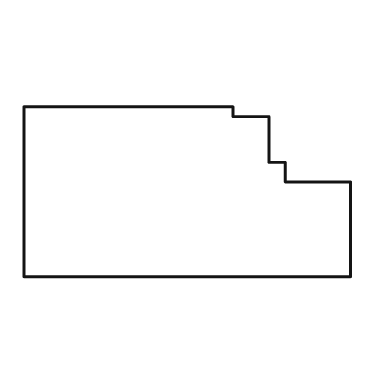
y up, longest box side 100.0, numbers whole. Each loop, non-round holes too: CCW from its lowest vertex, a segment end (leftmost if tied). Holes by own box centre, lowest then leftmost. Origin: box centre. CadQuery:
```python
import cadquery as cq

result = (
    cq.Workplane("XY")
    .moveTo(-50.0, -26.0)
    .lineTo(50.0, -26.0)
    .lineTo(50.0, 3.0)
    .lineTo(30.0, 3.0)
    .lineTo(30.0, 9.0)
    .lineTo(25.0, 9.0)
    .lineTo(25.0, 23.0)
    .lineTo(14.0, 23.0)
    .lineTo(14.0, 26.0)
    .lineTo(-50.0, 26.0)
    .close()
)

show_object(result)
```